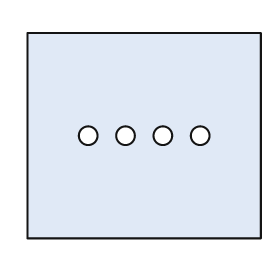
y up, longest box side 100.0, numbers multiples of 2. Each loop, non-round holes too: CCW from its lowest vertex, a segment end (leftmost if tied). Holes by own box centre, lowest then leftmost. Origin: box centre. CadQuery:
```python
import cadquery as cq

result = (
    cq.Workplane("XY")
    .moveTo(-50.0, -44.0)
    .lineTo(50.0, -44.0)
    .lineTo(50.0, 44.0)
    .lineTo(-50.0, 44.0)
    .close()
    .moveTo(-24.0, 0.0)
    .circle(4.0)
    .moveTo(-8.0, 0.0)
    .circle(4.0)
    .moveTo(8.0, 0.0)
    .circle(4.0)
    .moveTo(24.0, 0.0)
    .circle(4.0)
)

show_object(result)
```